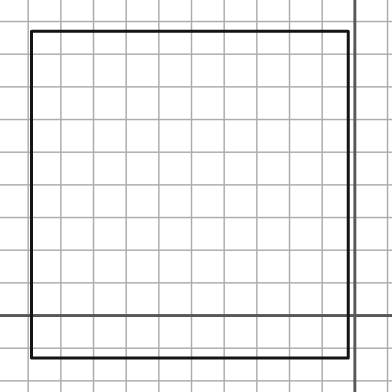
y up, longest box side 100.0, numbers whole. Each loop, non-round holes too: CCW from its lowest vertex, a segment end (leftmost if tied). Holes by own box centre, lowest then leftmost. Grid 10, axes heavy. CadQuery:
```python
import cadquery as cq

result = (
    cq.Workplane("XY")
    .moveTo(-99.0, -13.0)
    .lineTo(-2.0, -13.0)
    .lineTo(-2.0, 87.0)
    .lineTo(-99.0, 87.0)
    .close()
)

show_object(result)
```